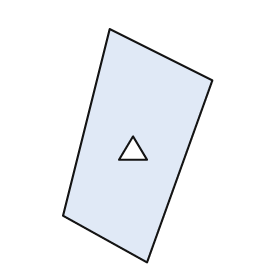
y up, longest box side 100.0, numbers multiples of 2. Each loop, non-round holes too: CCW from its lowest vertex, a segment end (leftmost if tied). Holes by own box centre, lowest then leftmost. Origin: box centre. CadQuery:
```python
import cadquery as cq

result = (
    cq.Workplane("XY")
    .moveTo(4.0, -50.0)
    .lineTo(32.0, 28.0)
    .lineTo(-12.0, 50.0)
    .lineTo(-32.0, -30.0)
    .close()
    .moveTo(-8.0, -6.0)
    .lineTo(4.0, -6.0)
    .lineTo(-2.0, 4.0)
    .close()
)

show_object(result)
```